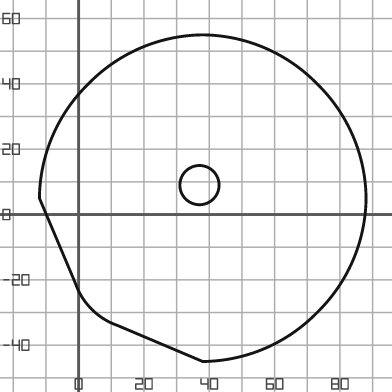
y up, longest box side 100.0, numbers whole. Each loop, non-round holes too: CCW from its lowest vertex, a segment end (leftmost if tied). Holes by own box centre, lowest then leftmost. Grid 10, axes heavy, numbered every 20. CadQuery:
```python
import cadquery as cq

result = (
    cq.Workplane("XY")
    .moveTo(38.0, -45.0)
    .threePointArc((57.0, -41.0), (73.0, -30.0))
    .threePointArc((84.0, -14.0), (88.0, 5.0))
    .threePointArc((84.0, 24.0), (73.0, 40.0))
    .threePointArc((57.0, 51.0), (38.0, 55.0))
    .threePointArc((19.0, 51.0), (3.0, 40.0))
    .threePointArc((-8.0, 24.0), (-12.0, 5.0))
    .lineTo(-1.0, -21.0)
    .threePointArc((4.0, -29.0), (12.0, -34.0))
    .close()
    .moveTo(37.0, 9.0)
    .circle(6.0)
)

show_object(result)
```